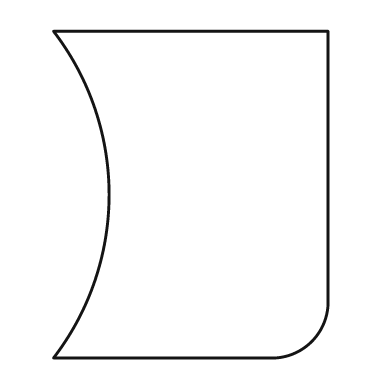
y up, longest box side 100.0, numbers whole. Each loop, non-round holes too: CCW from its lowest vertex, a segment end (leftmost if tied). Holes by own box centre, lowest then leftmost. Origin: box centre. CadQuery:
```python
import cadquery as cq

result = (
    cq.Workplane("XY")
    .moveTo(-42.0, -50.0)
    .lineTo(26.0, -50.0)
    .threePointArc((37.0, -45.0), (42.0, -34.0))
    .lineTo(42.0, 50.0)
    .lineTo(-42.0, 50.0)
    .threePointArc((-25.0, 0.0), (-42.0, -50.0))
    .close()
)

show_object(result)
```